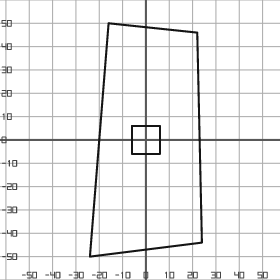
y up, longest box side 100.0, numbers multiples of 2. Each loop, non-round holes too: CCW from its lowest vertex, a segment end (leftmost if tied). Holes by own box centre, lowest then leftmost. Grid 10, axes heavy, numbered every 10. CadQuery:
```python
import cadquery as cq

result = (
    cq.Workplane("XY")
    .moveTo(-24.0, -50.0)
    .lineTo(24.0, -44.0)
    .lineTo(22.0, 46.0)
    .lineTo(-16.0, 50.0)
    .close()
    .moveTo(-6.0, -6.0)
    .lineTo(6.0, -6.0)
    .lineTo(6.0, 6.0)
    .lineTo(-6.0, 6.0)
    .close()
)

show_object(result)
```